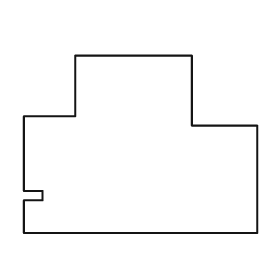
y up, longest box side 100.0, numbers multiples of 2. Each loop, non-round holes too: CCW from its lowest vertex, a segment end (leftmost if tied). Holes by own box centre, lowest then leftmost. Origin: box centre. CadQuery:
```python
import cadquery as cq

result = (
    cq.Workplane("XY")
    .moveTo(-50.0, -38.0)
    .lineTo(50.0, -38.0)
    .lineTo(50.0, 8.0)
    .lineTo(22.0, 8.0)
    .lineTo(22.0, 38.0)
    .lineTo(-28.0, 38.0)
    .lineTo(-28.0, 12.0)
    .lineTo(-50.0, 12.0)
    .lineTo(-50.0, -20.0)
    .lineTo(-42.0, -20.0)
    .lineTo(-42.0, -24.0)
    .lineTo(-50.0, -24.0)
    .close()
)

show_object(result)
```